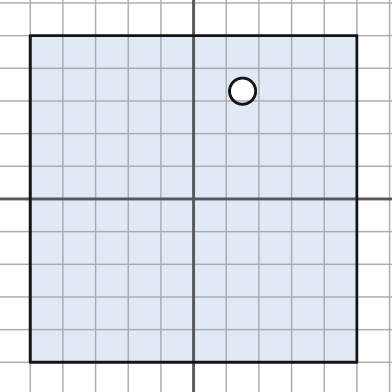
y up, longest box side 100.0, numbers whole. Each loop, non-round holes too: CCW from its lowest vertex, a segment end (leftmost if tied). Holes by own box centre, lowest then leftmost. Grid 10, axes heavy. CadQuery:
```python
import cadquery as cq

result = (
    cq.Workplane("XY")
    .moveTo(-50.0, -50.0)
    .lineTo(50.0, -50.0)
    .lineTo(50.0, 50.0)
    .lineTo(-50.0, 50.0)
    .close()
    .moveTo(15.0, 33.0)
    .circle(4.0)
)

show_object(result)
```